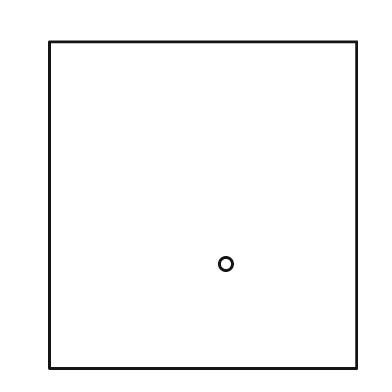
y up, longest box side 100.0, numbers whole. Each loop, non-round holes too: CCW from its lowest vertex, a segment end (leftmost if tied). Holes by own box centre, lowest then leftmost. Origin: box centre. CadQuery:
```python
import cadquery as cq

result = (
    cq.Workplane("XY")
    .moveTo(-47.0, -50.0)
    .lineTo(47.0, -50.0)
    .lineTo(47.0, 50.0)
    .lineTo(-47.0, 50.0)
    .close()
    .moveTo(7.0, -18.0)
    .circle(2.0)
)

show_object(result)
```